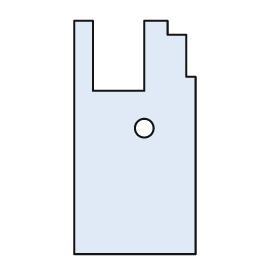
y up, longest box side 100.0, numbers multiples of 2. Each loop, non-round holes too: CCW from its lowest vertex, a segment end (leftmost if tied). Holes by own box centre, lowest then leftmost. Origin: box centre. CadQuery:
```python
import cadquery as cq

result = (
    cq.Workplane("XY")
    .moveTo(-26.0, -50.0)
    .lineTo(26.0, -50.0)
    .lineTo(26.0, 26.0)
    .lineTo(22.0, 26.0)
    .lineTo(22.0, 44.0)
    .lineTo(14.0, 44.0)
    .lineTo(14.0, 50.0)
    .lineTo(4.0, 50.0)
    .lineTo(4.0, 20.0)
    .lineTo(-18.0, 20.0)
    .lineTo(-18.0, 50.0)
    .lineTo(-26.0, 50.0)
    .close()
    .moveTo(4.0, 4.0)
    .circle(4.0)
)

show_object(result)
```